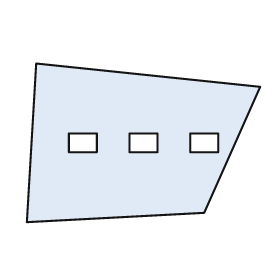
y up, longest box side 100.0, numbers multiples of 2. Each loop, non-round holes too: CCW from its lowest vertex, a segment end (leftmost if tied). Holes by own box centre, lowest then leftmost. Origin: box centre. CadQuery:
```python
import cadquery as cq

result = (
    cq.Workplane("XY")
    .moveTo(-50.0, -34.0)
    .lineTo(26.0, -30.0)
    .lineTo(50.0, 24.0)
    .lineTo(-46.0, 34.0)
    .close()
    .moveTo(-32.0, -4.0)
    .lineTo(-20.0, -4.0)
    .lineTo(-20.0, 4.0)
    .lineTo(-32.0, 4.0)
    .close()
    .moveTo(-6.0, -4.0)
    .lineTo(6.0, -4.0)
    .lineTo(6.0, 4.0)
    .lineTo(-6.0, 4.0)
    .close()
    .moveTo(20.0, -4.0)
    .lineTo(32.0, -4.0)
    .lineTo(32.0, 4.0)
    .lineTo(20.0, 4.0)
    .close()
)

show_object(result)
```